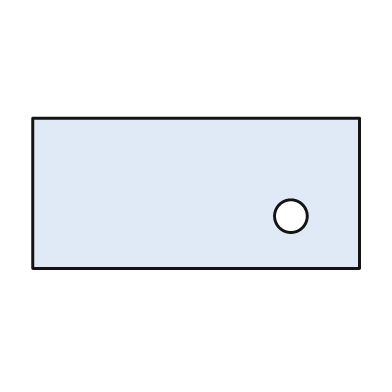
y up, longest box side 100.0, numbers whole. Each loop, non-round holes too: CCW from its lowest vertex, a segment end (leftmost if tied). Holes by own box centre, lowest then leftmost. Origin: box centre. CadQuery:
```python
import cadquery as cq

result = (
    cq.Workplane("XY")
    .moveTo(-50.0, -23.0)
    .lineTo(50.0, -23.0)
    .lineTo(50.0, 23.0)
    .lineTo(-50.0, 23.0)
    .close()
    .moveTo(29.0, -7.0)
    .circle(5.0)
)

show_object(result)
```